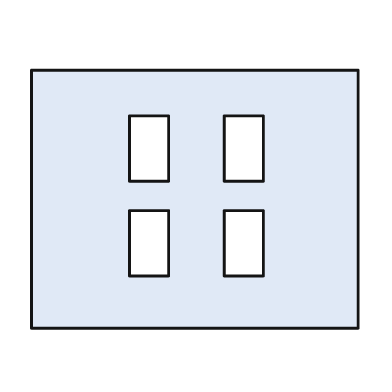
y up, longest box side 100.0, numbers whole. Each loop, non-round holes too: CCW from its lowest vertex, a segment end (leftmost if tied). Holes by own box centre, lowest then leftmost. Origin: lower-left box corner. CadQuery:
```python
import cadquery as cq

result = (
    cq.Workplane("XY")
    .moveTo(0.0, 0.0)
    .lineTo(100.0, 0.0)
    .lineTo(100.0, 79.0)
    .lineTo(0.0, 79.0)
    .close()
    .moveTo(30.0, 16.0)
    .lineTo(42.0, 16.0)
    .lineTo(42.0, 36.0)
    .lineTo(30.0, 36.0)
    .close()
    .moveTo(59.0, 16.0)
    .lineTo(71.0, 16.0)
    .lineTo(71.0, 36.0)
    .lineTo(59.0, 36.0)
    .close()
    .moveTo(30.0, 45.0)
    .lineTo(42.0, 45.0)
    .lineTo(42.0, 65.0)
    .lineTo(30.0, 65.0)
    .close()
    .moveTo(59.0, 45.0)
    .lineTo(71.0, 45.0)
    .lineTo(71.0, 65.0)
    .lineTo(59.0, 65.0)
    .close()
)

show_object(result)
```